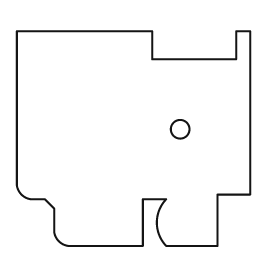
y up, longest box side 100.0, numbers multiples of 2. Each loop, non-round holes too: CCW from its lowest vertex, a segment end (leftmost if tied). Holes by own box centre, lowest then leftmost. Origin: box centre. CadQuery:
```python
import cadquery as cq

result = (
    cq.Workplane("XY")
    .moveTo(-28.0, -46.0)
    .lineTo(4.0, -46.0)
    .lineTo(4.0, -26.0)
    .lineTo(14.0, -26.0)
    .threePointArc((10.0, -36.0), (14.0, -46.0))
    .lineTo(36.0, -46.0)
    .lineTo(36.0, -24.0)
    .lineTo(50.0, -24.0)
    .lineTo(50.0, 46.0)
    .lineTo(44.0, 46.0)
    .lineTo(44.0, 34.0)
    .lineTo(8.0, 34.0)
    .lineTo(8.0, 46.0)
    .lineTo(-50.0, 46.0)
    .lineTo(-50.0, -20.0)
    .threePointArc((-48.0, -24.0), (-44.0, -26.0))
    .lineTo(-38.0, -26.0)
    .lineTo(-34.0, -30.0)
    .lineTo(-34.0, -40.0)
    .threePointArc((-32.0, -44.0), (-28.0, -46.0))
    .close()
    .moveTo(20.0, 4.0)
    .circle(4.0)
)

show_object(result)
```